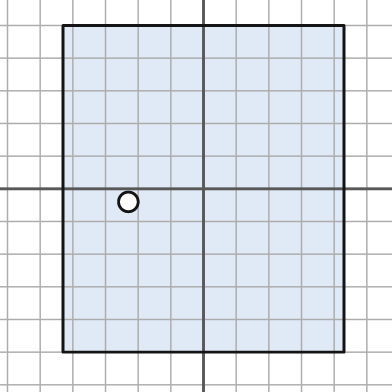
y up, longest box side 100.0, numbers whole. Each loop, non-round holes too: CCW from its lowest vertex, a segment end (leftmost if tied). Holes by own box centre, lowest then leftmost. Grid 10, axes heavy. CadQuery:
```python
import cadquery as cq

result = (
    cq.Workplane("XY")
    .moveTo(-43.0, -50.0)
    .lineTo(43.0, -50.0)
    .lineTo(43.0, 50.0)
    .lineTo(-43.0, 50.0)
    .close()
    .moveTo(-23.0, -4.0)
    .circle(3.0)
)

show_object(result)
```